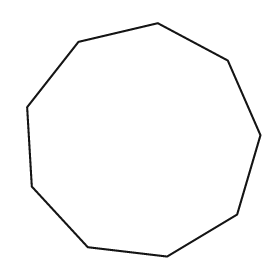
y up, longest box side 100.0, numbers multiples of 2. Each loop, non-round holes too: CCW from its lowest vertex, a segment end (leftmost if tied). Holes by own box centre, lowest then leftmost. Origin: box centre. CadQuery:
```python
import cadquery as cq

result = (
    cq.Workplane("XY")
    .moveTo(10.0, -50.0)
    .lineTo(40.0, -32.0)
    .lineTo(50.0, 2.0)
    .lineTo(36.0, 34.0)
    .lineTo(6.0, 50.0)
    .lineTo(-28.0, 42.0)
    .lineTo(-50.0, 14.0)
    .lineTo(-48.0, -20.0)
    .lineTo(-24.0, -46.0)
    .close()
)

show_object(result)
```